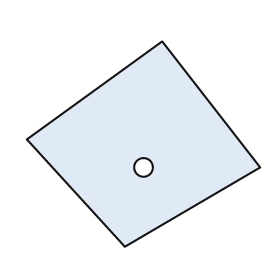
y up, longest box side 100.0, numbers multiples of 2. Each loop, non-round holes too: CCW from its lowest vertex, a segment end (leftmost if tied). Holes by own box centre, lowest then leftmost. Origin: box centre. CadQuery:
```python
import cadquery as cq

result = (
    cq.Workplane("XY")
    .moveTo(-8.0, -44.0)
    .lineTo(50.0, -10.0)
    .lineTo(8.0, 44.0)
    .lineTo(-50.0, 2.0)
    .close()
    .moveTo(0.0, -10.0)
    .circle(4.0)
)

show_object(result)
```